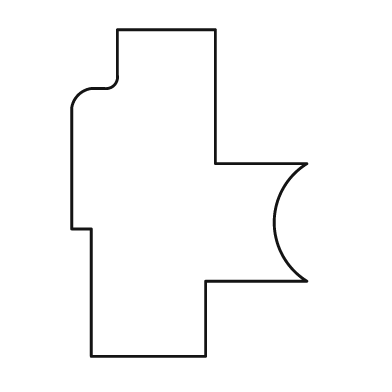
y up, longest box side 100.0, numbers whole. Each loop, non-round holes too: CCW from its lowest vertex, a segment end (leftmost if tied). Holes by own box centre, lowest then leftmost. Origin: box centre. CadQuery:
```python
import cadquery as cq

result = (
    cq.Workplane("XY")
    .moveTo(-30.0, -50.0)
    .lineTo(5.0, -50.0)
    .lineTo(5.0, -27.0)
    .lineTo(36.0, -27.0)
    .threePointArc((26.0, -9.0), (36.0, 9.0))
    .lineTo(8.0, 9.0)
    .lineTo(8.0, 50.0)
    .lineTo(-22.0, 50.0)
    .lineTo(-22.0, 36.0)
    .threePointArc((-23.0, 33.0), (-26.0, 32.0))
    .lineTo(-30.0, 32.0)
    .threePointArc((-34.0, 30.0), (-36.0, 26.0))
    .lineTo(-36.0, -11.0)
    .lineTo(-30.0, -11.0)
    .close()
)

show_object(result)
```